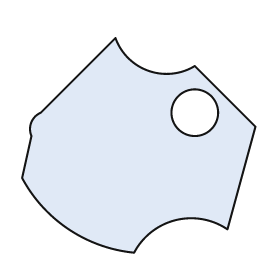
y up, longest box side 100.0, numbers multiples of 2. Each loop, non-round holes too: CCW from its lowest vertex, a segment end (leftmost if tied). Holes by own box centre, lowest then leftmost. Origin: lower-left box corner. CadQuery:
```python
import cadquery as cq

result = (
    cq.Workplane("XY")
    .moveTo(48.0, 0.0)
    .threePointArc((66.0, 14.0), (88.0, 10.0))
    .lineTo(100.0, 54.0)
    .lineTo(74.0, 80.0)
    .threePointArc((54.0, 78.0), (40.0, 92.0))
    .lineTo(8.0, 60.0)
    .threePointArc((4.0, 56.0), (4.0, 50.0))
    .lineTo(0.0, 32.0)
    .threePointArc((20.0, 10.0), (48.0, 0.0))
    .close()
    .moveTo(74.0, 60.0)
    .circle(10.0)
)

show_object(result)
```